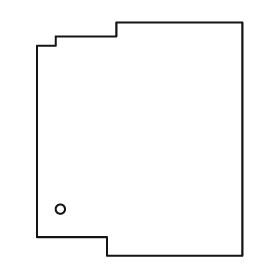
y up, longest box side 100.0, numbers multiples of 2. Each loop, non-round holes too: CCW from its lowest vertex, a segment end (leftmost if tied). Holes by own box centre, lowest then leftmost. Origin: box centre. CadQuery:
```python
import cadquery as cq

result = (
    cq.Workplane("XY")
    .moveTo(-14.0, -50.0)
    .lineTo(44.0, -50.0)
    .lineTo(44.0, 50.0)
    .lineTo(-10.0, 50.0)
    .lineTo(-10.0, 44.0)
    .lineTo(-36.0, 44.0)
    .lineTo(-36.0, 40.0)
    .lineTo(-44.0, 40.0)
    .lineTo(-44.0, -42.0)
    .lineTo(-14.0, -42.0)
    .close()
    .moveTo(-34.0, -30.0)
    .circle(2.0)
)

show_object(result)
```